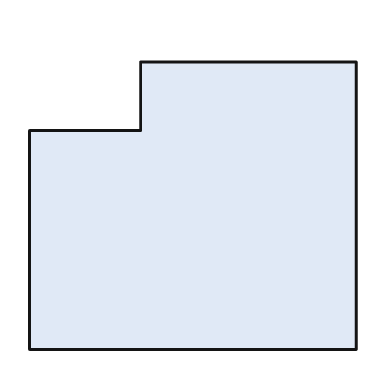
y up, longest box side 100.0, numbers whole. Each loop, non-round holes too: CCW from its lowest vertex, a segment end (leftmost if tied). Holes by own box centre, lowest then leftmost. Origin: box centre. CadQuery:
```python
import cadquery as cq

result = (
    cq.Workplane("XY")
    .moveTo(-50.0, -44.0)
    .lineTo(50.0, -44.0)
    .lineTo(50.0, 44.0)
    .lineTo(-16.0, 44.0)
    .lineTo(-16.0, 23.0)
    .lineTo(-50.0, 23.0)
    .close()
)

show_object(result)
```